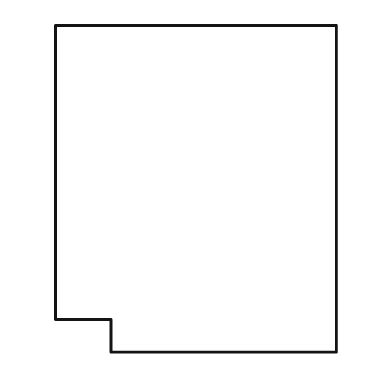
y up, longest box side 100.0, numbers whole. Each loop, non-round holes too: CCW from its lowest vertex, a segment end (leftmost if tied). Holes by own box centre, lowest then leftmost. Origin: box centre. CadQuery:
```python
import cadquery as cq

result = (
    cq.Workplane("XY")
    .moveTo(-26.0, -50.0)
    .lineTo(43.0, -50.0)
    .lineTo(43.0, 50.0)
    .lineTo(-43.0, 50.0)
    .lineTo(-43.0, -40.0)
    .lineTo(-26.0, -40.0)
    .close()
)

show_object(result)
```